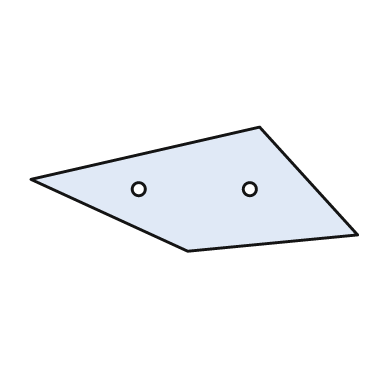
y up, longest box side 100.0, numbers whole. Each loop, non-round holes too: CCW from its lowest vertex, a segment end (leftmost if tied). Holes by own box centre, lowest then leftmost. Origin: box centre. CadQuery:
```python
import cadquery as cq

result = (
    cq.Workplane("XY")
    .moveTo(-2.0, -19.0)
    .lineTo(50.0, -14.0)
    .lineTo(20.0, 19.0)
    .lineTo(-50.0, 3.0)
    .close()
    .moveTo(-17.0, 0.0)
    .circle(2.0)
    .moveTo(17.0, 0.0)
    .circle(2.0)
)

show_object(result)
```